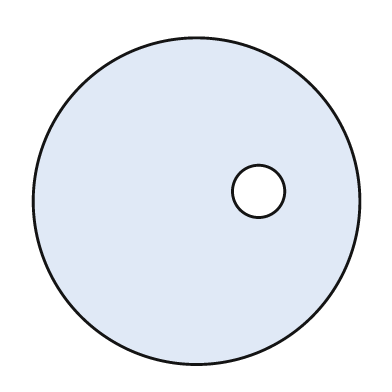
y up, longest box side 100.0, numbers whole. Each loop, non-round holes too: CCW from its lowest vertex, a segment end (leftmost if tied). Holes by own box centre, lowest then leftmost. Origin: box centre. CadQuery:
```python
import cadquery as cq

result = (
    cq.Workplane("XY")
    .moveTo(0.0, 0.0)
    .circle(50.0)
    .moveTo(19.0, 3.0)
    .circle(8.0)
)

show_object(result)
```